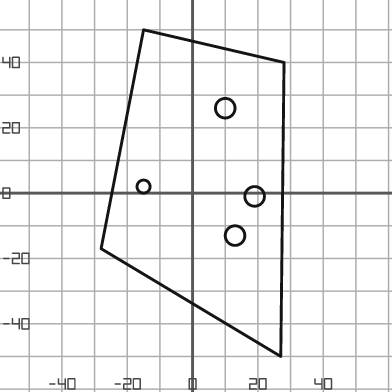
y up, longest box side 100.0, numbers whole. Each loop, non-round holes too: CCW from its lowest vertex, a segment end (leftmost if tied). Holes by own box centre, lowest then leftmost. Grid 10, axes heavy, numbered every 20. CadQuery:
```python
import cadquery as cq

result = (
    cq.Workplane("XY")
    .moveTo(27.0, -50.0)
    .lineTo(28.0, 40.0)
    .lineTo(-15.0, 50.0)
    .lineTo(-28.0, -17.0)
    .close()
    .moveTo(13.0, -13.0)
    .circle(3.0)
    .moveTo(19.0, -1.0)
    .circle(3.0)
    .moveTo(-15.0, 2.0)
    .circle(2.0)
    .moveTo(10.0, 26.0)
    .circle(3.0)
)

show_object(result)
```